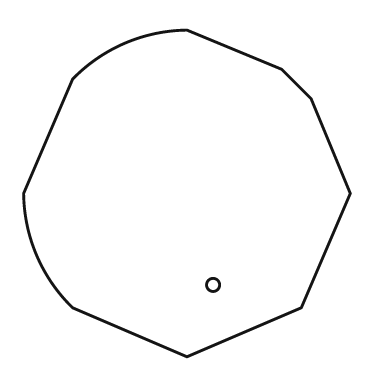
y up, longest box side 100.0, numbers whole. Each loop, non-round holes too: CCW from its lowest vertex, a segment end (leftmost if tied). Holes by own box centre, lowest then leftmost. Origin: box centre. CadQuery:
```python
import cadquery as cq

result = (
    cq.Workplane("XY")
    .moveTo(0.0, -50.0)
    .lineTo(35.0, -35.0)
    .lineTo(50.0, 0.0)
    .lineTo(38.0, 29.0)
    .lineTo(29.0, 38.0)
    .lineTo(0.0, 50.0)
    .threePointArc((-19.0, 46.0), (-35.0, 35.0))
    .lineTo(-50.0, 0.0)
    .threePointArc((-46.0, -19.0), (-35.0, -35.0))
    .close()
    .moveTo(8.0, -28.0)
    .circle(2.0)
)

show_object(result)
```